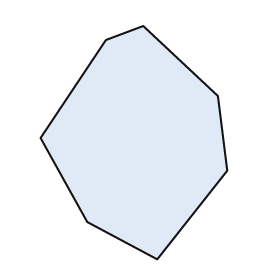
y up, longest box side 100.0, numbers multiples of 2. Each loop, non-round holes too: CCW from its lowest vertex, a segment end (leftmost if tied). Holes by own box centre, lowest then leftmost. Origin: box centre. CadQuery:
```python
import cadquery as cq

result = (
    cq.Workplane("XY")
    .moveTo(10.0, -50.0)
    .lineTo(40.0, -12.0)
    .lineTo(36.0, 20.0)
    .lineTo(4.0, 50.0)
    .lineTo(-12.0, 44.0)
    .lineTo(-40.0, 2.0)
    .lineTo(-20.0, -34.0)
    .close()
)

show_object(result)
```